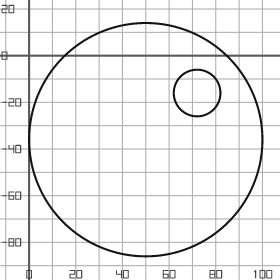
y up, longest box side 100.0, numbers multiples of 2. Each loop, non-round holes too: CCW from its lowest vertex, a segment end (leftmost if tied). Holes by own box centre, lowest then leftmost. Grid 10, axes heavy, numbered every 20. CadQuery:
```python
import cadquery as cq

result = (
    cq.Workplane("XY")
    .moveTo(50.0, -36.0)
    .circle(50.0)
    .moveTo(72.0, -16.0)
    .circle(10.0)
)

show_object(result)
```